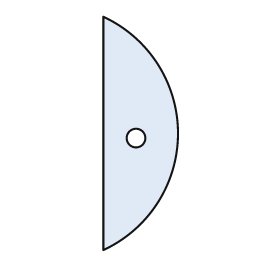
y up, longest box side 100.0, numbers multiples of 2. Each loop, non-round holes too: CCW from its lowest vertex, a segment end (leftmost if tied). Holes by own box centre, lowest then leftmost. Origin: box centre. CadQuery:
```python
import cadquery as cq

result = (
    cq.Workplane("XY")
    .moveTo(-16.0, -50.0)
    .threePointArc((16.0, 0.0), (-16.0, 50.0))
    .close()
    .moveTo(-2.0, -2.0)
    .circle(4.0)
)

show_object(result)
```